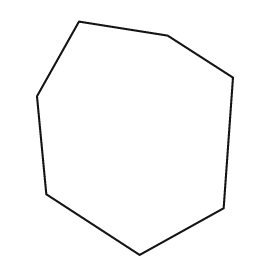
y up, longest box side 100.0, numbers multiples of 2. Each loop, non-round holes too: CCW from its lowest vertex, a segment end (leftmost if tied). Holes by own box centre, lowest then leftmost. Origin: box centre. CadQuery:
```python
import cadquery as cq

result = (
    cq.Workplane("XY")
    .moveTo(2.0, -50.0)
    .lineTo(38.0, -30.0)
    .lineTo(42.0, 26.0)
    .lineTo(14.0, 44.0)
    .lineTo(-24.0, 50.0)
    .lineTo(-42.0, 18.0)
    .lineTo(-38.0, -24.0)
    .close()
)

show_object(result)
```